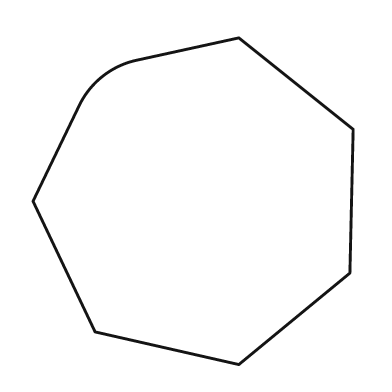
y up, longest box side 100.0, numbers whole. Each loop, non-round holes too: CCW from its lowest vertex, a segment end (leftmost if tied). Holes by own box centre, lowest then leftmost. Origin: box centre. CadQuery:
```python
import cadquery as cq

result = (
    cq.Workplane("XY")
    .moveTo(14.0, -50.0)
    .lineTo(48.0, -22.0)
    .lineTo(49.0, 22.0)
    .lineTo(14.0, 50.0)
    .lineTo(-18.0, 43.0)
    .threePointArc((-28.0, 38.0), (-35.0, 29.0))
    .lineTo(-49.0, 0.0)
    .lineTo(-30.0, -40.0)
    .close()
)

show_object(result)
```